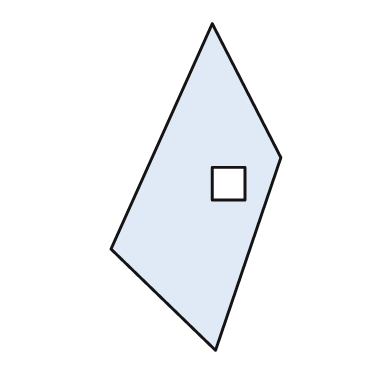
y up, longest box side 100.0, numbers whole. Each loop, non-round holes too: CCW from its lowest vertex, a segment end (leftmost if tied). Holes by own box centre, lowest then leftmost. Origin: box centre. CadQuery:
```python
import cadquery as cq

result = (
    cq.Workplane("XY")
    .moveTo(6.0, -50.0)
    .lineTo(26.0, 9.0)
    .lineTo(5.0, 50.0)
    .lineTo(-26.0, -19.0)
    .close()
    .moveTo(5.0, -4.0)
    .lineTo(15.0, -4.0)
    .lineTo(15.0, 6.0)
    .lineTo(5.0, 6.0)
    .close()
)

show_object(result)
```